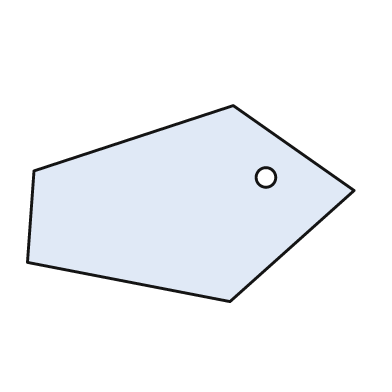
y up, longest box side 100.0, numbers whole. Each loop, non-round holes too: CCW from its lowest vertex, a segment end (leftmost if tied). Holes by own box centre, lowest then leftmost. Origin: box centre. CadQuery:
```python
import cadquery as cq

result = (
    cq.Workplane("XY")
    .moveTo(12.0, -30.0)
    .lineTo(50.0, 4.0)
    .lineTo(13.0, 30.0)
    .lineTo(-48.0, 10.0)
    .lineTo(-50.0, -18.0)
    .close()
    .moveTo(23.0, 8.0)
    .circle(3.0)
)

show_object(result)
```